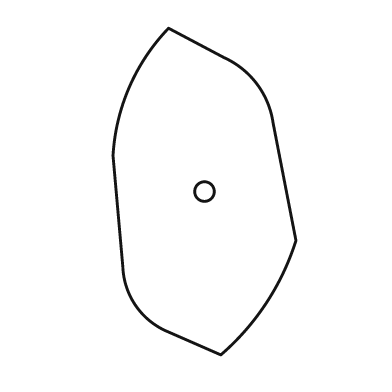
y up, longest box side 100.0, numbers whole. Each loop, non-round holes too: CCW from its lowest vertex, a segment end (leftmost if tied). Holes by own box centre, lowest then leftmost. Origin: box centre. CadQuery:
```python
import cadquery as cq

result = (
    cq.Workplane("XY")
    .moveTo(5.0, -50.0)
    .threePointArc((19.0, -34.0), (28.0, -15.0))
    .lineTo(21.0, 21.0)
    .threePointArc((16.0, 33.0), (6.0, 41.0))
    .lineTo(-11.0, 50.0)
    .threePointArc((-23.0, 32.0), (-28.0, 11.0))
    .lineTo(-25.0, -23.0)
    .threePointArc((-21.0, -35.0), (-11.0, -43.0))
    .close()
    .moveTo(0.0, 0.0)
    .circle(3.0)
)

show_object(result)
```